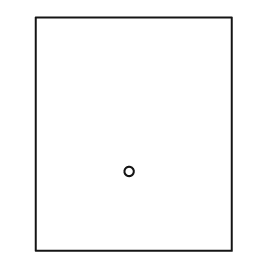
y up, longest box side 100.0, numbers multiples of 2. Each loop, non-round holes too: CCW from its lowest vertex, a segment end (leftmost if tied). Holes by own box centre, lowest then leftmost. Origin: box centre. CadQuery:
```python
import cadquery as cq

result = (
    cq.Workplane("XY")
    .moveTo(-42.0, -50.0)
    .lineTo(42.0, -50.0)
    .lineTo(42.0, 50.0)
    .lineTo(-42.0, 50.0)
    .close()
    .moveTo(-2.0, -16.0)
    .circle(2.0)
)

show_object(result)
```